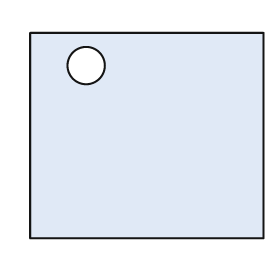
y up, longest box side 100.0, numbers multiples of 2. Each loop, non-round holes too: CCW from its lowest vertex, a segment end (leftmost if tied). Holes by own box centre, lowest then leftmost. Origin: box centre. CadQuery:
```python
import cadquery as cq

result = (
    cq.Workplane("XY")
    .moveTo(-50.0, -44.0)
    .lineTo(50.0, -44.0)
    .lineTo(50.0, 44.0)
    .lineTo(-50.0, 44.0)
    .close()
    .moveTo(-26.0, 30.0)
    .circle(8.0)
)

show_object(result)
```